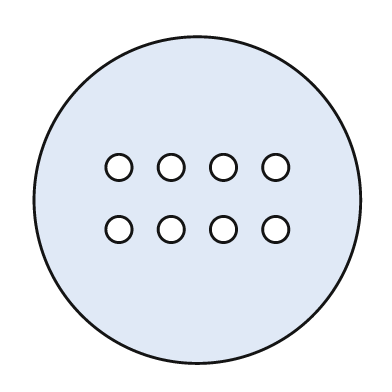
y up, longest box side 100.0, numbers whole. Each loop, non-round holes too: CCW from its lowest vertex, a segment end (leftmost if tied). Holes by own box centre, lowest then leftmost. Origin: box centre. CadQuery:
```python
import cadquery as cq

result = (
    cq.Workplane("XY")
    .moveTo(0.0, 0.0)
    .circle(50.0)
    .moveTo(-24.0, -9.0)
    .circle(4.0)
    .moveTo(-8.0, -9.0)
    .circle(4.0)
    .moveTo(8.0, -9.0)
    .circle(4.0)
    .moveTo(24.0, -9.0)
    .circle(4.0)
    .moveTo(-24.0, 10.0)
    .circle(4.0)
    .moveTo(-8.0, 10.0)
    .circle(4.0)
    .moveTo(8.0, 10.0)
    .circle(4.0)
    .moveTo(24.0, 10.0)
    .circle(4.0)
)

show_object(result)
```